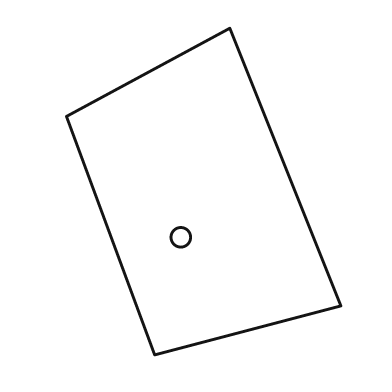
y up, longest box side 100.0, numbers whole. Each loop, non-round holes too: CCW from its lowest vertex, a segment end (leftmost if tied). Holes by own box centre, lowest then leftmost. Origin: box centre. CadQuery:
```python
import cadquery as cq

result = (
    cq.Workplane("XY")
    .moveTo(-15.0, -50.0)
    .lineTo(42.0, -35.0)
    .lineTo(8.0, 50.0)
    .lineTo(-42.0, 23.0)
    .close()
    .moveTo(-7.0, -14.0)
    .circle(3.0)
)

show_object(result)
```